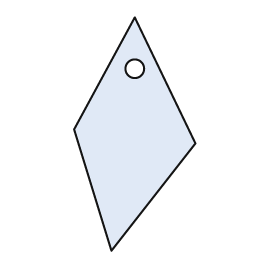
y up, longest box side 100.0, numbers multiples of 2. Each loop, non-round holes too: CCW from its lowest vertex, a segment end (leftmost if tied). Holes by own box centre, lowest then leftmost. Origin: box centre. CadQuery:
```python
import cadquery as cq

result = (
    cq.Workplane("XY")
    .moveTo(-10.0, -50.0)
    .lineTo(26.0, -4.0)
    .lineTo(0.0, 50.0)
    .lineTo(-26.0, 2.0)
    .close()
    .moveTo(0.0, 28.0)
    .circle(4.0)
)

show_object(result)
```